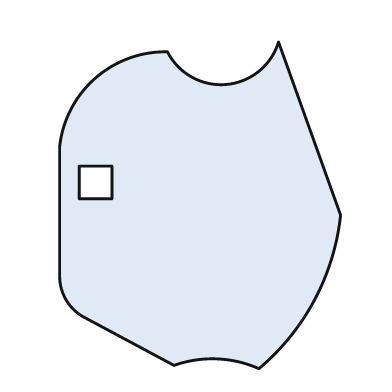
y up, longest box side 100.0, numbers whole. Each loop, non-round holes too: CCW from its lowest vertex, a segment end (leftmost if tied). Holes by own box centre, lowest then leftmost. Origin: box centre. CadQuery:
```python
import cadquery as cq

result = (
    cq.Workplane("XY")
    .moveTo(18.0, -50.0)
    .threePointArc((35.0, -29.0), (43.0, -3.0))
    .lineTo(24.0, 50.0)
    .threePointArc((8.0, 37.0), (-10.0, 47.0))
    .threePointArc((-32.0, 39.0), (-43.0, 18.0))
    .lineTo(-43.0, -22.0)
    .threePointArc((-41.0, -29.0), (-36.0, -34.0))
    .lineTo(-8.0, -49.0)
    .threePointArc((5.0, -47.0), (18.0, -50.0))
    .close()
    .moveTo(-37.0, 2.0)
    .lineTo(-27.0, 2.0)
    .lineTo(-27.0, 12.0)
    .lineTo(-37.0, 12.0)
    .close()
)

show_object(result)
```